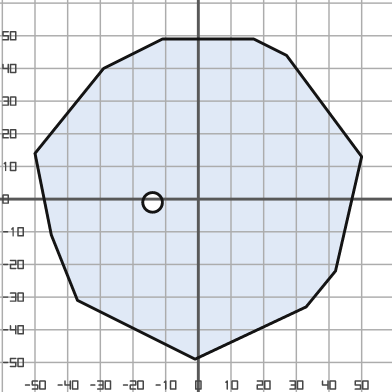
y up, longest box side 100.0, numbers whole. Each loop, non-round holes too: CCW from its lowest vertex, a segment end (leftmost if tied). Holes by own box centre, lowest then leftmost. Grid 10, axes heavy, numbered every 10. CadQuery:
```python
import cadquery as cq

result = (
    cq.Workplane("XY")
    .moveTo(-1.0, -49.0)
    .lineTo(33.0, -33.0)
    .lineTo(42.0, -22.0)
    .lineTo(50.0, 13.0)
    .lineTo(27.0, 44.0)
    .lineTo(17.0, 49.0)
    .lineTo(-11.0, 49.0)
    .lineTo(-29.0, 40.0)
    .lineTo(-50.0, 14.0)
    .lineTo(-45.0, -11.0)
    .lineTo(-37.0, -31.0)
    .close()
    .moveTo(-14.0, -1.0)
    .circle(3.0)
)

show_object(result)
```